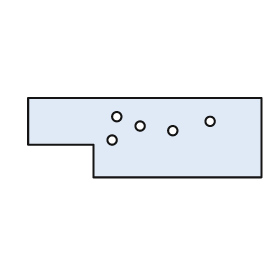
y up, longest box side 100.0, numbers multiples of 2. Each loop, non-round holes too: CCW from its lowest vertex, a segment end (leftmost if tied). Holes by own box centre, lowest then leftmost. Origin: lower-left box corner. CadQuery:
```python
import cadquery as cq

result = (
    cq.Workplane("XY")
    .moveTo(28.0, 0.0)
    .lineTo(100.0, 0.0)
    .lineTo(100.0, 34.0)
    .lineTo(0.0, 34.0)
    .lineTo(0.0, 14.0)
    .lineTo(28.0, 14.0)
    .close()
    .moveTo(36.0, 16.0)
    .circle(2.0)
    .moveTo(62.0, 20.0)
    .circle(2.0)
    .moveTo(48.0, 22.0)
    .circle(2.0)
    .moveTo(78.0, 24.0)
    .circle(2.0)
    .moveTo(38.0, 26.0)
    .circle(2.0)
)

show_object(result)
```